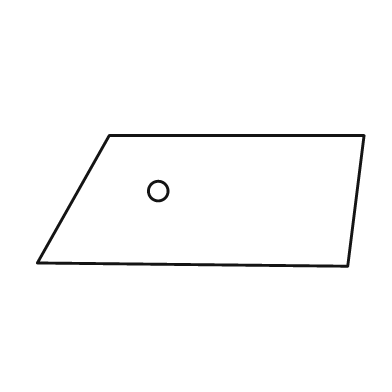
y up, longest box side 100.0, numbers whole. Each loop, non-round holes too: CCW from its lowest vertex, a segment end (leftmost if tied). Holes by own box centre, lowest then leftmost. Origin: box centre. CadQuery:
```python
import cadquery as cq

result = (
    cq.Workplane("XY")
    .moveTo(45.0, -20.0)
    .lineTo(50.0, 20.0)
    .lineTo(-28.0, 20.0)
    .lineTo(-50.0, -19.0)
    .close()
    .moveTo(-13.0, 3.0)
    .circle(3.0)
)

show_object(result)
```